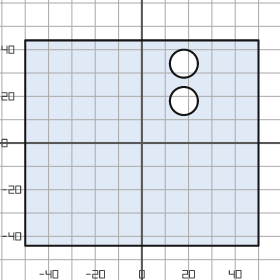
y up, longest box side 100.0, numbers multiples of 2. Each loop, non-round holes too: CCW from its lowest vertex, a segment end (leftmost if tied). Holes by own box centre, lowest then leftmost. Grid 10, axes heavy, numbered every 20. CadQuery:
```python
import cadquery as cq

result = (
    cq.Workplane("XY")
    .moveTo(-50.0, -44.0)
    .lineTo(50.0, -44.0)
    .lineTo(50.0, 44.0)
    .lineTo(-50.0, 44.0)
    .close()
    .moveTo(18.0, 18.0)
    .circle(6.0)
    .moveTo(18.0, 34.0)
    .circle(6.0)
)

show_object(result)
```